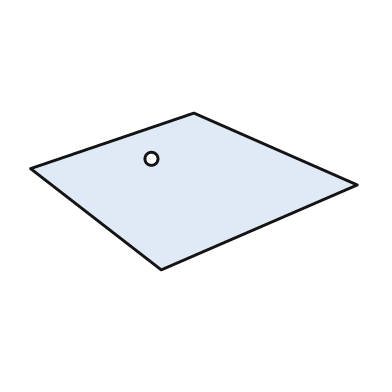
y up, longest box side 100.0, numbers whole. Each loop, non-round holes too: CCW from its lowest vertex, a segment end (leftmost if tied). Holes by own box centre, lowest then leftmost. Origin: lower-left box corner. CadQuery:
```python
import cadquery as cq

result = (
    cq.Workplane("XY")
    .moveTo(40.0, 0.0)
    .lineTo(100.0, 26.0)
    .lineTo(50.0, 48.0)
    .lineTo(0.0, 31.0)
    .close()
    .moveTo(37.0, 34.0)
    .circle(2.0)
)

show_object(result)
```